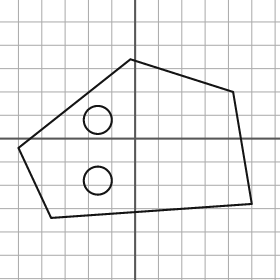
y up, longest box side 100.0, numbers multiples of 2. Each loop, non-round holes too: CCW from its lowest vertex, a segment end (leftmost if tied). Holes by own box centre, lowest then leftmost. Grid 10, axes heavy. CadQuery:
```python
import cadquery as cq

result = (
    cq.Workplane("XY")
    .moveTo(-36.0, -34.0)
    .lineTo(50.0, -28.0)
    .lineTo(42.0, 20.0)
    .lineTo(-2.0, 34.0)
    .lineTo(-50.0, -4.0)
    .close()
    .moveTo(-16.0, -18.0)
    .circle(6.0)
    .moveTo(-16.0, 8.0)
    .circle(6.0)
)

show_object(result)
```